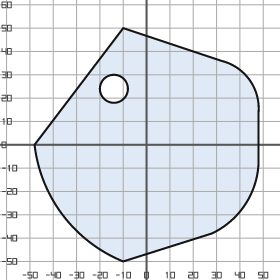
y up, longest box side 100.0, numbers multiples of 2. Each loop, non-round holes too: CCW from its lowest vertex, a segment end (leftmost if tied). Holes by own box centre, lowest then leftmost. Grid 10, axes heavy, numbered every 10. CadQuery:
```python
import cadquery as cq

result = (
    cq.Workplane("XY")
    .moveTo(-10.0, -50.0)
    .lineTo(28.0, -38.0)
    .threePointArc((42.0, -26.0), (48.0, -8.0))
    .lineTo(48.0, 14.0)
    .threePointArc((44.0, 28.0), (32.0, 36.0))
    .lineTo(-10.0, 50.0)
    .lineTo(-48.0, 0.0)
    .threePointArc((-36.0, -30.0), (-10.0, -50.0))
    .close()
    .moveTo(-14.0, 24.0)
    .circle(6.0)
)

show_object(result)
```